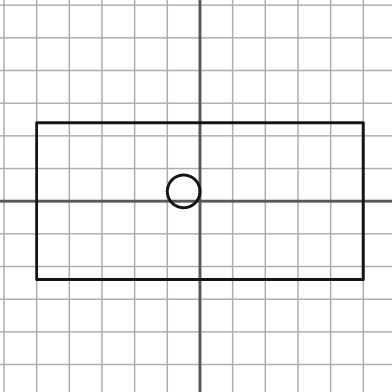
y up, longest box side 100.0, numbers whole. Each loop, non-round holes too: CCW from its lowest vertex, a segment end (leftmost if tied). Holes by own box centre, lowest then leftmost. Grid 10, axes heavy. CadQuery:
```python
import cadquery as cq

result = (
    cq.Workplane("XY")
    .moveTo(-50.0, -24.0)
    .lineTo(50.0, -24.0)
    .lineTo(50.0, 24.0)
    .lineTo(-50.0, 24.0)
    .close()
    .moveTo(-5.0, 3.0)
    .circle(5.0)
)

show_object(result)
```